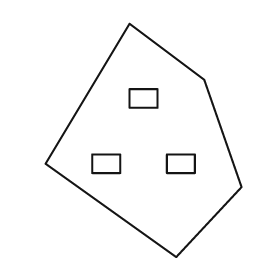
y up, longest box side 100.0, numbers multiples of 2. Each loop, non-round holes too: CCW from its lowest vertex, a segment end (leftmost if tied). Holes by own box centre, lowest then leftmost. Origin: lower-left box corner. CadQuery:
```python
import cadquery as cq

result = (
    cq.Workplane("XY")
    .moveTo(56.0, 0.0)
    .lineTo(84.0, 30.0)
    .lineTo(68.0, 76.0)
    .lineTo(36.0, 100.0)
    .lineTo(0.0, 40.0)
    .close()
    .moveTo(20.0, 36.0)
    .lineTo(32.0, 36.0)
    .lineTo(32.0, 44.0)
    .lineTo(20.0, 44.0)
    .close()
    .moveTo(52.0, 36.0)
    .lineTo(64.0, 36.0)
    .lineTo(64.0, 44.0)
    .lineTo(52.0, 44.0)
    .close()
    .moveTo(36.0, 64.0)
    .lineTo(48.0, 64.0)
    .lineTo(48.0, 72.0)
    .lineTo(36.0, 72.0)
    .close()
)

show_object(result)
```